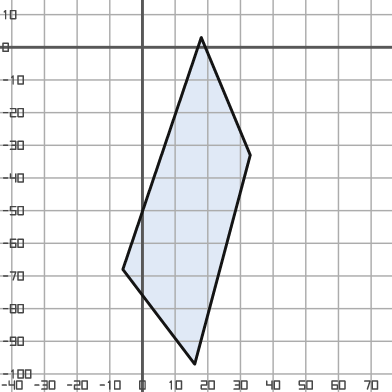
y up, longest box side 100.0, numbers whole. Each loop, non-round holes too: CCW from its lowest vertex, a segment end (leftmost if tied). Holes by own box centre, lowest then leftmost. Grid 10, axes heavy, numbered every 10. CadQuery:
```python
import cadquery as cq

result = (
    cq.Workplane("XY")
    .moveTo(16.0, -97.0)
    .lineTo(33.0, -33.0)
    .lineTo(18.0, 3.0)
    .lineTo(-6.0, -68.0)
    .close()
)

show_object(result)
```